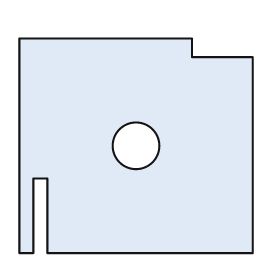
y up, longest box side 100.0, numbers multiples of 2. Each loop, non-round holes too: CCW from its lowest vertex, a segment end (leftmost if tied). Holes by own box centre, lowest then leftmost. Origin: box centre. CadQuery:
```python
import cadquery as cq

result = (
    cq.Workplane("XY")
    .moveTo(-50.0, -46.0)
    .lineTo(-44.0, -46.0)
    .lineTo(-44.0, -14.0)
    .lineTo(-38.0, -14.0)
    .lineTo(-38.0, -46.0)
    .lineTo(50.0, -46.0)
    .lineTo(50.0, 38.0)
    .lineTo(24.0, 38.0)
    .lineTo(24.0, 46.0)
    .lineTo(-50.0, 46.0)
    .close()
    .moveTo(0.0, 0.0)
    .circle(10.0)
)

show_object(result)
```